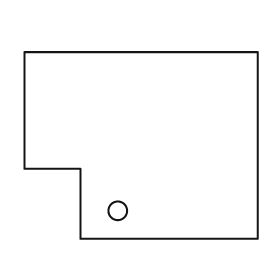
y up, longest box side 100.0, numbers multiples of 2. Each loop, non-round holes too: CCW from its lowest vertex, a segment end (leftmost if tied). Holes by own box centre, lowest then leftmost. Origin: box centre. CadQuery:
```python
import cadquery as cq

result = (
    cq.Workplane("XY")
    .moveTo(-26.0, -40.0)
    .lineTo(50.0, -40.0)
    .lineTo(50.0, 40.0)
    .lineTo(-50.0, 40.0)
    .lineTo(-50.0, -10.0)
    .lineTo(-26.0, -10.0)
    .close()
    .moveTo(-10.0, -28.0)
    .circle(4.0)
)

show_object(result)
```